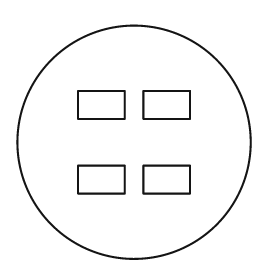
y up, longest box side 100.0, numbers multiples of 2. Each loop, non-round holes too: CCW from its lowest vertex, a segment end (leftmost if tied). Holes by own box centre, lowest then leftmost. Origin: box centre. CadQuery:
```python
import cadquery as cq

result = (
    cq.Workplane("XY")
    .moveTo(0.0, 0.0)
    .circle(50.0)
    .moveTo(-24.0, -22.0)
    .lineTo(-4.0, -22.0)
    .lineTo(-4.0, -10.0)
    .lineTo(-24.0, -10.0)
    .close()
    .moveTo(4.0, -22.0)
    .lineTo(24.0, -22.0)
    .lineTo(24.0, -10.0)
    .lineTo(4.0, -10.0)
    .close()
    .moveTo(-24.0, 10.0)
    .lineTo(-4.0, 10.0)
    .lineTo(-4.0, 22.0)
    .lineTo(-24.0, 22.0)
    .close()
    .moveTo(4.0, 10.0)
    .lineTo(24.0, 10.0)
    .lineTo(24.0, 22.0)
    .lineTo(4.0, 22.0)
    .close()
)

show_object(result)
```